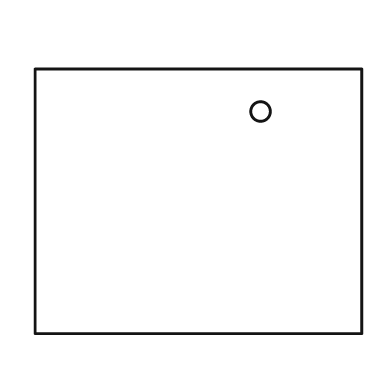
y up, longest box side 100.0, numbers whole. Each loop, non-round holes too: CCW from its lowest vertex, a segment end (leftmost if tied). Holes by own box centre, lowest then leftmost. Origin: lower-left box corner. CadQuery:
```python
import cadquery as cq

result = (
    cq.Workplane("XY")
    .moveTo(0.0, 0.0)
    .lineTo(100.0, 0.0)
    .lineTo(100.0, 81.0)
    .lineTo(0.0, 81.0)
    .close()
    .moveTo(69.0, 68.0)
    .circle(3.0)
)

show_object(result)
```